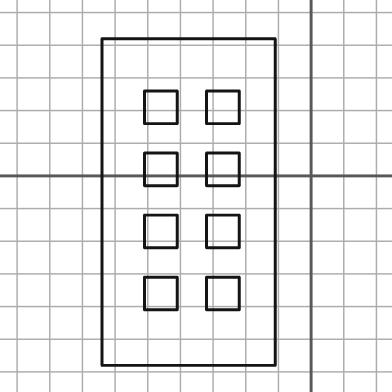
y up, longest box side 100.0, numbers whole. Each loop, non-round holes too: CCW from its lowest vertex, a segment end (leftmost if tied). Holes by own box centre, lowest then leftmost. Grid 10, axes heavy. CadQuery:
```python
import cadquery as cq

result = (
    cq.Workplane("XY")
    .moveTo(-64.0, -58.0)
    .lineTo(-11.0, -58.0)
    .lineTo(-11.0, 42.0)
    .lineTo(-64.0, 42.0)
    .close()
    .moveTo(-51.0, -41.0)
    .lineTo(-41.0, -41.0)
    .lineTo(-41.0, -31.0)
    .lineTo(-51.0, -31.0)
    .close()
    .moveTo(-32.0, -41.0)
    .lineTo(-22.0, -41.0)
    .lineTo(-22.0, -31.0)
    .lineTo(-32.0, -31.0)
    .close()
    .moveTo(-51.0, -22.0)
    .lineTo(-41.0, -22.0)
    .lineTo(-41.0, -12.0)
    .lineTo(-51.0, -12.0)
    .close()
    .moveTo(-32.0, -22.0)
    .lineTo(-22.0, -22.0)
    .lineTo(-22.0, -12.0)
    .lineTo(-32.0, -12.0)
    .close()
    .moveTo(-51.0, -3.0)
    .lineTo(-41.0, -3.0)
    .lineTo(-41.0, 7.0)
    .lineTo(-51.0, 7.0)
    .close()
    .moveTo(-32.0, -3.0)
    .lineTo(-22.0, -3.0)
    .lineTo(-22.0, 7.0)
    .lineTo(-32.0, 7.0)
    .close()
    .moveTo(-51.0, 16.0)
    .lineTo(-41.0, 16.0)
    .lineTo(-41.0, 26.0)
    .lineTo(-51.0, 26.0)
    .close()
    .moveTo(-32.0, 16.0)
    .lineTo(-22.0, 16.0)
    .lineTo(-22.0, 26.0)
    .lineTo(-32.0, 26.0)
    .close()
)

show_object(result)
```